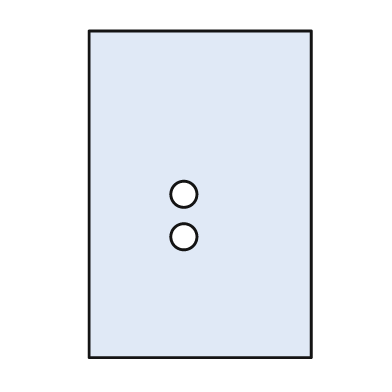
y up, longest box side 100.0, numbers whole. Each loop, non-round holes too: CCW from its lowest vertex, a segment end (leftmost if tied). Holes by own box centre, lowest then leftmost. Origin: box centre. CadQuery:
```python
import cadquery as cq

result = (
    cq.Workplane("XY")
    .moveTo(-34.0, -50.0)
    .lineTo(34.0, -50.0)
    .lineTo(34.0, 50.0)
    .lineTo(-34.0, 50.0)
    .close()
    .moveTo(-5.0, -13.0)
    .circle(4.0)
    .moveTo(-5.0, 0.0)
    .circle(4.0)
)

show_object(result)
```